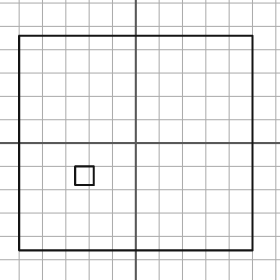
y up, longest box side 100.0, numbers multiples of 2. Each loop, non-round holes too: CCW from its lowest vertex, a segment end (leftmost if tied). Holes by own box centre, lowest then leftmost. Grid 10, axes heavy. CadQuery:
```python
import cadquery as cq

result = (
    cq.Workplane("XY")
    .moveTo(-50.0, -46.0)
    .lineTo(50.0, -46.0)
    .lineTo(50.0, 46.0)
    .lineTo(-50.0, 46.0)
    .close()
    .moveTo(-26.0, -18.0)
    .lineTo(-18.0, -18.0)
    .lineTo(-18.0, -10.0)
    .lineTo(-26.0, -10.0)
    .close()
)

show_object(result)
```